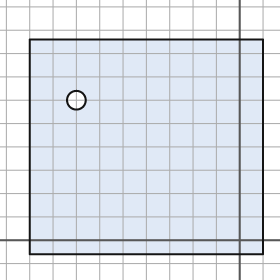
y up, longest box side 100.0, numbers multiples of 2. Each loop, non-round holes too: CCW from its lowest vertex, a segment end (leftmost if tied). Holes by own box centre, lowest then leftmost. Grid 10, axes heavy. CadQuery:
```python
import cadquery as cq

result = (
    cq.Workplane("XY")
    .moveTo(-90.0, -6.0)
    .lineTo(10.0, -6.0)
    .lineTo(10.0, 86.0)
    .lineTo(-90.0, 86.0)
    .close()
    .moveTo(-70.0, 60.0)
    .circle(4.0)
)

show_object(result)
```